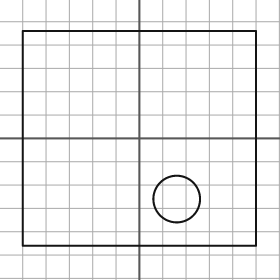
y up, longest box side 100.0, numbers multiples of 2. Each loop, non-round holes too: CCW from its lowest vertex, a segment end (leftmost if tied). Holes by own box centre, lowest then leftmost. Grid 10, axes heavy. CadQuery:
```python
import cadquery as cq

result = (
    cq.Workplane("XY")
    .moveTo(-50.0, -46.0)
    .lineTo(50.0, -46.0)
    .lineTo(50.0, 46.0)
    .lineTo(-50.0, 46.0)
    .close()
    .moveTo(16.0, -26.0)
    .circle(10.0)
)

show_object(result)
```